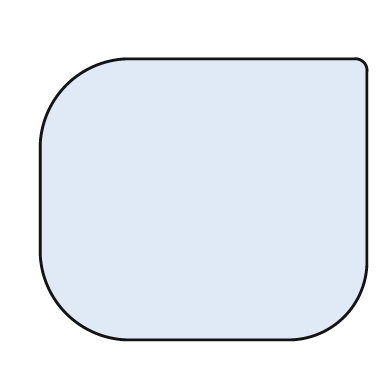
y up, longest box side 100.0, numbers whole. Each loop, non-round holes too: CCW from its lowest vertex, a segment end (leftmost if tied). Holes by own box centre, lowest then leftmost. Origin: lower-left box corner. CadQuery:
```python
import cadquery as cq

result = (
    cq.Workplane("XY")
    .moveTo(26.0, 0.0)
    .lineTo(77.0, 0.0)
    .threePointArc((93.0, 7.0), (100.0, 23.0))
    .lineTo(100.0, 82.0)
    .threePointArc((99.0, 85.0), (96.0, 86.0))
    .lineTo(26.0, 86.0)
    .threePointArc((8.0, 78.0), (0.0, 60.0))
    .lineTo(0.0, 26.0)
    .threePointArc((8.0, 8.0), (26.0, 0.0))
    .close()
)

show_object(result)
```